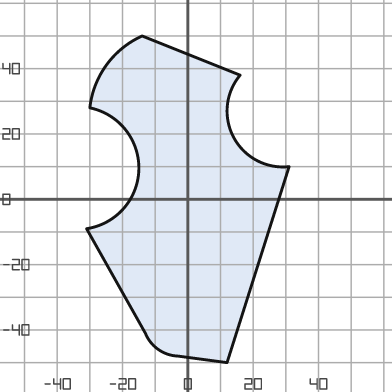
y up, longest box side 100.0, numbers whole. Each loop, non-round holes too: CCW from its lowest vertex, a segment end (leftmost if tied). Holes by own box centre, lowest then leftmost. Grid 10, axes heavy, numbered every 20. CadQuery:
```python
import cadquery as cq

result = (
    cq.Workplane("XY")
    .moveTo(12.0, -50.0)
    .lineTo(31.0, 10.0)
    .threePointArc((14.0, 19.0), (16.0, 38.0))
    .lineTo(-14.0, 50.0)
    .threePointArc((-25.0, 41.0), (-30.0, 28.0))
    .threePointArc((-15.0, 9.0), (-31.0, -9.0))
    .lineTo(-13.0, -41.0)
    .threePointArc((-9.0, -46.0), (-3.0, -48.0))
    .close()
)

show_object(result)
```